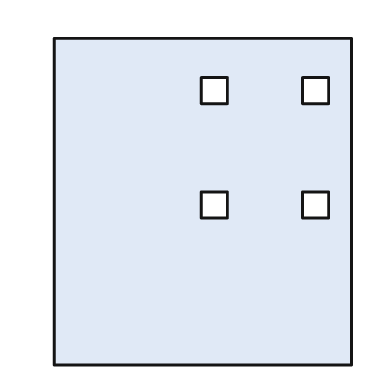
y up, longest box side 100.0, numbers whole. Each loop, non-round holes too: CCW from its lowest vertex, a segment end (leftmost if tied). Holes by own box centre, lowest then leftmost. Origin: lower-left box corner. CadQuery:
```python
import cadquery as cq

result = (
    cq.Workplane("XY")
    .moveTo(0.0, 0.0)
    .lineTo(91.0, 0.0)
    .lineTo(91.0, 100.0)
    .lineTo(0.0, 100.0)
    .close()
    .moveTo(45.0, 45.0)
    .lineTo(53.0, 45.0)
    .lineTo(53.0, 53.0)
    .lineTo(45.0, 53.0)
    .close()
    .moveTo(76.0, 45.0)
    .lineTo(84.0, 45.0)
    .lineTo(84.0, 53.0)
    .lineTo(76.0, 53.0)
    .close()
    .moveTo(45.0, 80.0)
    .lineTo(53.0, 80.0)
    .lineTo(53.0, 88.0)
    .lineTo(45.0, 88.0)
    .close()
    .moveTo(76.0, 80.0)
    .lineTo(84.0, 80.0)
    .lineTo(84.0, 88.0)
    .lineTo(76.0, 88.0)
    .close()
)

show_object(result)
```